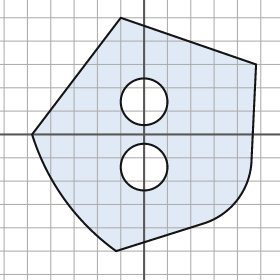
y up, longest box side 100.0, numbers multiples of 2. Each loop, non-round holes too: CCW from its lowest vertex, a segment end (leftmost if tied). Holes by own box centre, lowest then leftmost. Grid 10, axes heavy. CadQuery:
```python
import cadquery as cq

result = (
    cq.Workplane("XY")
    .moveTo(-12.0, -50.0)
    .lineTo(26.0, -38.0)
    .threePointArc((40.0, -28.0), (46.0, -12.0))
    .lineTo(48.0, 30.0)
    .lineTo(-10.0, 50.0)
    .lineTo(-48.0, 0.0)
    .threePointArc((-34.0, -28.0), (-12.0, -50.0))
    .close()
    .moveTo(0.0, -14.0)
    .circle(10.0)
    .moveTo(0.0, 14.0)
    .circle(10.0)
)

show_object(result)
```